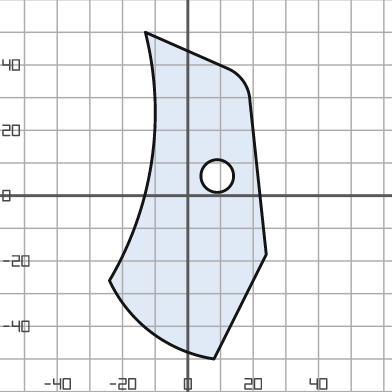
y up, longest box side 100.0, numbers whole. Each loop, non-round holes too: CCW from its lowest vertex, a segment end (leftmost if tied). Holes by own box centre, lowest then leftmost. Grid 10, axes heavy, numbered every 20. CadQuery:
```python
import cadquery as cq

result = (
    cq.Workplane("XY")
    .moveTo(8.0, -50.0)
    .lineTo(24.0, -18.0)
    .lineTo(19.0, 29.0)
    .threePointArc((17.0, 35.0), (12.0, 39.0))
    .lineTo(-13.0, 50.0)
    .threePointArc((-11.0, 11.0), (-24.0, -26.0))
    .threePointArc((-11.0, -42.0), (8.0, -50.0))
    .close()
    .moveTo(9.0, 6.0)
    .circle(5.0)
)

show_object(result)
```